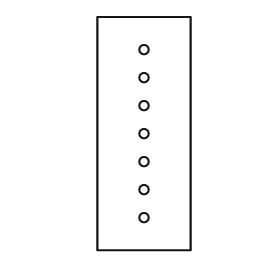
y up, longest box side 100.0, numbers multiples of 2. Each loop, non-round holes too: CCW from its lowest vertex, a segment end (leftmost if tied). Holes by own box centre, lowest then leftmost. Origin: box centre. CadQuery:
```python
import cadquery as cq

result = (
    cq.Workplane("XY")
    .moveTo(-20.0, -50.0)
    .lineTo(20.0, -50.0)
    .lineTo(20.0, 50.0)
    .lineTo(-20.0, 50.0)
    .close()
    .moveTo(0.0, -36.0)
    .circle(2.0)
    .moveTo(0.0, -24.0)
    .circle(2.0)
    .moveTo(0.0, -12.0)
    .circle(2.0)
    .moveTo(0.0, 0.0)
    .circle(2.0)
    .moveTo(0.0, 12.0)
    .circle(2.0)
    .moveTo(0.0, 24.0)
    .circle(2.0)
    .moveTo(0.0, 36.0)
    .circle(2.0)
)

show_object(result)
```